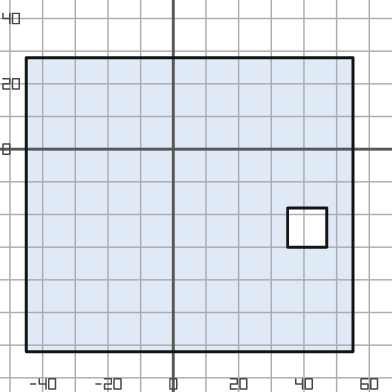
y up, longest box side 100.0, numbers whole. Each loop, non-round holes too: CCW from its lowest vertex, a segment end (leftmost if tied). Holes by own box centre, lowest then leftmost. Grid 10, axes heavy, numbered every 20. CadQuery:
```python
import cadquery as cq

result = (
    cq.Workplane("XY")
    .moveTo(-45.0, -62.0)
    .lineTo(55.0, -62.0)
    .lineTo(55.0, 28.0)
    .lineTo(-45.0, 28.0)
    .close()
    .moveTo(35.0, -30.0)
    .lineTo(47.0, -30.0)
    .lineTo(47.0, -18.0)
    .lineTo(35.0, -18.0)
    .close()
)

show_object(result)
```